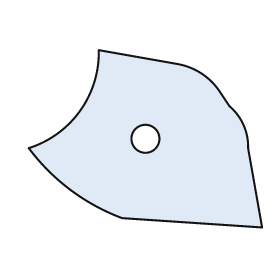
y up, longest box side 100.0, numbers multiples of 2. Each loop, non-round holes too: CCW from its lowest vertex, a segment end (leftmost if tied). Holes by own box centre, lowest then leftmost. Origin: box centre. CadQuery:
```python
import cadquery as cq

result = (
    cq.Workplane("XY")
    .moveTo(50.0, -38.0)
    .lineTo(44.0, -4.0)
    .threePointArc((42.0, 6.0), (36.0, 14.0))
    .lineTo(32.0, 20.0)
    .threePointArc((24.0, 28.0), (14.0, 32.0))
    .lineTo(-20.0, 38.0)
    .threePointArc((-28.0, 12.0), (-50.0, -4.0))
    .threePointArc((-32.0, -22.0), (-10.0, -34.0))
    .close()
    .moveTo(0.0, 0.0)
    .circle(6.0)
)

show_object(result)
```